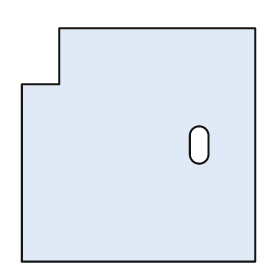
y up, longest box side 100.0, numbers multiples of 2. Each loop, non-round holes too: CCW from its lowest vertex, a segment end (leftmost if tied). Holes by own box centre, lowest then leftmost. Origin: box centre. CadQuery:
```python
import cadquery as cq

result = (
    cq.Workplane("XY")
    .moveTo(-50.0, -50.0)
    .lineTo(50.0, -50.0)
    .lineTo(50.0, 50.0)
    .lineTo(-34.0, 50.0)
    .lineTo(-34.0, 26.0)
    .lineTo(-50.0, 26.0)
    .close()
    .moveTo(22.0, -4.0)
    .threePointArc((26.0, -8.0), (30.0, -4.0))
    .lineTo(30.0, 4.0)
    .threePointArc((26.0, 8.0), (22.0, 4.0))
    .close()
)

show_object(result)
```